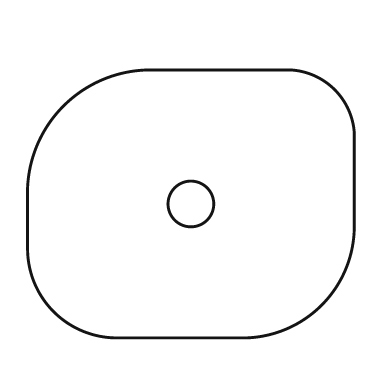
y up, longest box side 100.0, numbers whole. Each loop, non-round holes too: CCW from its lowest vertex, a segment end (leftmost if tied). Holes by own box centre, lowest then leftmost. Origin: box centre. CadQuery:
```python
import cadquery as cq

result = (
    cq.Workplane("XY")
    .moveTo(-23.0, -41.0)
    .lineTo(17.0, -41.0)
    .threePointArc((40.0, -31.0), (50.0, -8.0))
    .lineTo(50.0, 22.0)
    .threePointArc((44.0, 35.0), (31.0, 41.0))
    .lineTo(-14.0, 41.0)
    .threePointArc((-39.0, 30.0), (-50.0, 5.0))
    .lineTo(-50.0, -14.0)
    .threePointArc((-42.0, -33.0), (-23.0, -41.0))
    .close()
    .moveTo(0.0, 0.0)
    .circle(7.0)
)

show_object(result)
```